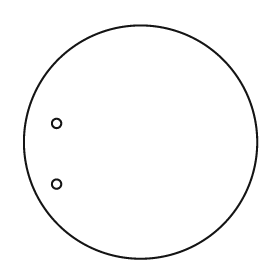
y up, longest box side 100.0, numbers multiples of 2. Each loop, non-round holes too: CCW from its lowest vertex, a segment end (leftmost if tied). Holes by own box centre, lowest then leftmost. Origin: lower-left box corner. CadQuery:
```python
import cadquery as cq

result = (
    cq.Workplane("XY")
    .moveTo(50.0, 50.0)
    .circle(50.0)
    .moveTo(14.0, 32.0)
    .circle(2.0)
    .moveTo(14.0, 58.0)
    .circle(2.0)
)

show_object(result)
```